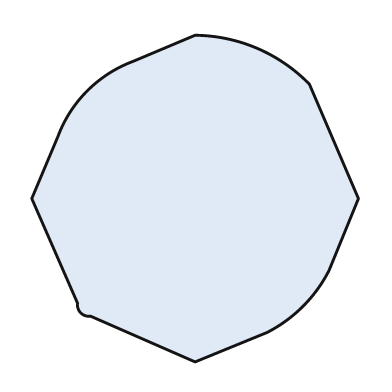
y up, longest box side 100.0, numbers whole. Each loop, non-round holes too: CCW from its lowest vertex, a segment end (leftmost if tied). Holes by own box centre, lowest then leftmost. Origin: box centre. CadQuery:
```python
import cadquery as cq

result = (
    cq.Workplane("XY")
    .moveTo(0.0, -50.0)
    .lineTo(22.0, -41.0)
    .threePointArc((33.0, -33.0), (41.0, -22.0))
    .lineTo(50.0, 0.0)
    .lineTo(35.0, 35.0)
    .threePointArc((19.0, 46.0), (0.0, 50.0))
    .lineTo(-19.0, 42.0)
    .threePointArc((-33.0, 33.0), (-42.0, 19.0))
    .lineTo(-50.0, 0.0)
    .lineTo(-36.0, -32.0)
    .threePointArc((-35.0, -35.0), (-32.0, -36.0))
    .close()
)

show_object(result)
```